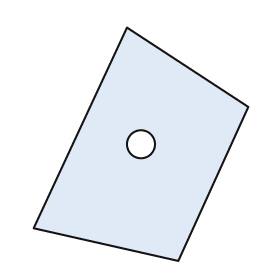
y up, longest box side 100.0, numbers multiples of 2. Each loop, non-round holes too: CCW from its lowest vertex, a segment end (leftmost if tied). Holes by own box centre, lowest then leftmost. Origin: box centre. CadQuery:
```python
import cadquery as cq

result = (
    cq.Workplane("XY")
    .moveTo(16.0, -50.0)
    .lineTo(46.0, 16.0)
    .lineTo(-6.0, 50.0)
    .lineTo(-46.0, -36.0)
    .close()
    .moveTo(0.0, 0.0)
    .circle(6.0)
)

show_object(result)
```